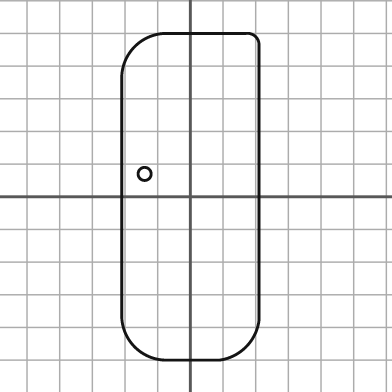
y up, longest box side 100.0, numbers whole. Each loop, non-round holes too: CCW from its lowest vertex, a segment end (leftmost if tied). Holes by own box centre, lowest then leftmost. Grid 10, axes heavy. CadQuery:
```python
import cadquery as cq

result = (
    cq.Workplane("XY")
    .moveTo(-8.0, -50.0)
    .lineTo(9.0, -50.0)
    .threePointArc((17.0, -46.0), (21.0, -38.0))
    .lineTo(21.0, 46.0)
    .threePointArc((20.0, 49.0), (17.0, 50.0))
    .lineTo(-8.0, 50.0)
    .threePointArc((-17.0, 46.0), (-21.0, 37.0))
    .lineTo(-21.0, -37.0)
    .threePointArc((-17.0, -46.0), (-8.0, -50.0))
    .close()
    .moveTo(-14.0, 7.0)
    .circle(2.0)
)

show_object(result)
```